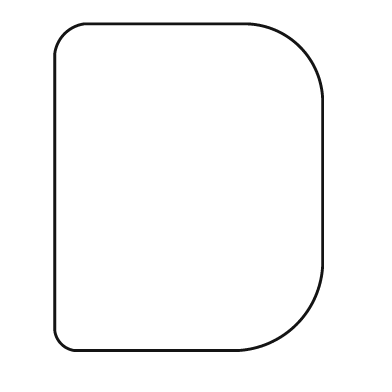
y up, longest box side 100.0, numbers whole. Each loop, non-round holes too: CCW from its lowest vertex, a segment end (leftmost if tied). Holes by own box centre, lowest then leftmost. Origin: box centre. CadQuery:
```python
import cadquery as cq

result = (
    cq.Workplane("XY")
    .moveTo(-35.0, -50.0)
    .lineTo(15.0, -50.0)
    .threePointArc((33.0, -42.0), (41.0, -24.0))
    .lineTo(41.0, 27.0)
    .threePointArc((34.0, 43.0), (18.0, 50.0))
    .lineTo(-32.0, 50.0)
    .threePointArc((-38.0, 47.0), (-41.0, 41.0))
    .lineTo(-41.0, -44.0)
    .threePointArc((-39.0, -48.0), (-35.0, -50.0))
    .close()
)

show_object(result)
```